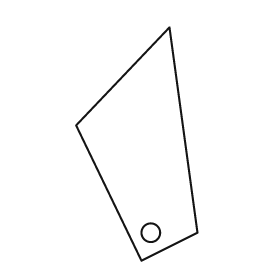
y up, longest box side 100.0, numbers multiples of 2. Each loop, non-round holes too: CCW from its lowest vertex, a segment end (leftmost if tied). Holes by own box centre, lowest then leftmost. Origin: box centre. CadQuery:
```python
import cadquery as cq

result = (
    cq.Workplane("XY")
    .moveTo(2.0, -50.0)
    .lineTo(26.0, -38.0)
    .lineTo(14.0, 50.0)
    .lineTo(-26.0, 8.0)
    .close()
    .moveTo(6.0, -38.0)
    .circle(4.0)
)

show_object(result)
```